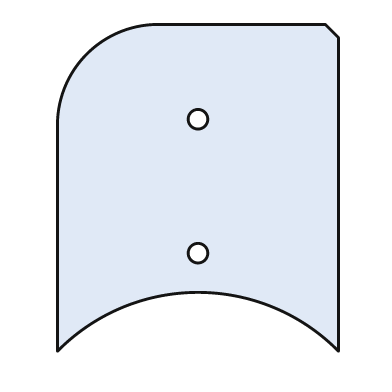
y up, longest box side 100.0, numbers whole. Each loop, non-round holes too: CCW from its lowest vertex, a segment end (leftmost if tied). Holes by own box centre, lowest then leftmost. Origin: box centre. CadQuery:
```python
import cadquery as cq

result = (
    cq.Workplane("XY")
    .moveTo(-43.0, -50.0)
    .threePointArc((0.0, -32.0), (43.0, -50.0))
    .lineTo(43.0, 46.0)
    .lineTo(39.0, 50.0)
    .lineTo(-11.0, 50.0)
    .threePointArc((-34.0, 41.0), (-43.0, 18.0))
    .close()
    .moveTo(0.0, -20.0)
    .circle(3.0)
    .moveTo(0.0, 21.0)
    .circle(3.0)
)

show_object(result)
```